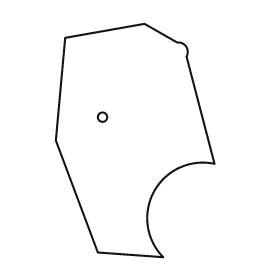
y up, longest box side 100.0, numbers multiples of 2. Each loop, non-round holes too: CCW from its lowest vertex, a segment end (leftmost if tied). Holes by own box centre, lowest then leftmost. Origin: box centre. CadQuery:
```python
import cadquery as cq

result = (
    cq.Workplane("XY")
    .moveTo(12.0, -50.0)
    .threePointArc((8.0, -22.0), (34.0, -10.0))
    .lineTo(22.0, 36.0)
    .threePointArc((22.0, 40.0), (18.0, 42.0))
    .lineTo(4.0, 50.0)
    .lineTo(-30.0, 44.0)
    .lineTo(-34.0, 0.0)
    .lineTo(-16.0, -48.0)
    .close()
    .moveTo(-14.0, 10.0)
    .circle(2.0)
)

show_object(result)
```